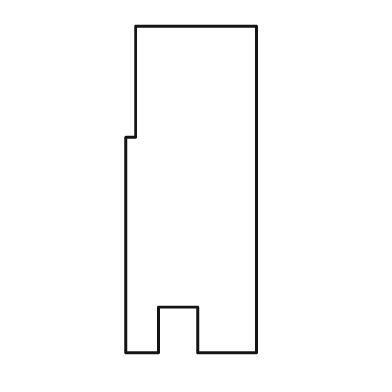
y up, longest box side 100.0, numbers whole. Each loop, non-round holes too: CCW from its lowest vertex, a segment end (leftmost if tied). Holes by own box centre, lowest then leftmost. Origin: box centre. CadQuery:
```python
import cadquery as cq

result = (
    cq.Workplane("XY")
    .moveTo(-20.0, -50.0)
    .lineTo(-10.0, -50.0)
    .lineTo(-10.0, -36.0)
    .lineTo(2.0, -36.0)
    .lineTo(2.0, -50.0)
    .lineTo(20.0, -50.0)
    .lineTo(20.0, 50.0)
    .lineTo(-17.0, 50.0)
    .lineTo(-17.0, 16.0)
    .lineTo(-20.0, 16.0)
    .close()
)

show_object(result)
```